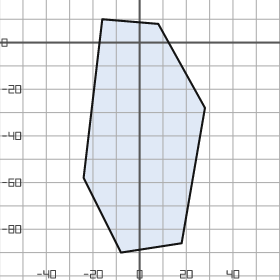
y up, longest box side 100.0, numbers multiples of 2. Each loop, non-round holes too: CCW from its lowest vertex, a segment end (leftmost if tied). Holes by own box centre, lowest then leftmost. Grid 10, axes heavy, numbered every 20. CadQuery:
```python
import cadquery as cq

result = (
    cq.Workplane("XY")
    .moveTo(-8.0, -90.0)
    .lineTo(18.0, -86.0)
    .lineTo(28.0, -28.0)
    .lineTo(8.0, 8.0)
    .lineTo(-16.0, 10.0)
    .lineTo(-24.0, -58.0)
    .close()
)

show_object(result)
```